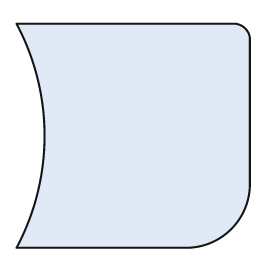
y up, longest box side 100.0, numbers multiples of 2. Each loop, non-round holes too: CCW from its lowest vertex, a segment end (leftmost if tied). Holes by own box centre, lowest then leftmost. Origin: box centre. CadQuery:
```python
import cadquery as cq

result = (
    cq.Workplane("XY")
    .moveTo(-50.0, -48.0)
    .lineTo(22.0, -48.0)
    .threePointArc((42.0, -40.0), (50.0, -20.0))
    .lineTo(50.0, 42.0)
    .threePointArc((48.0, 46.0), (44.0, 48.0))
    .lineTo(-50.0, 48.0)
    .threePointArc((-38.0, 0.0), (-50.0, -48.0))
    .close()
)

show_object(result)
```